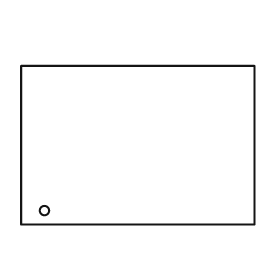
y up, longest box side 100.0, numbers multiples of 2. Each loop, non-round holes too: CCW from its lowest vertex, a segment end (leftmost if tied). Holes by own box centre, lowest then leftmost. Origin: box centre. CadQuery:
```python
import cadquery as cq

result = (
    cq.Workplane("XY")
    .moveTo(-50.0, -34.0)
    .lineTo(50.0, -34.0)
    .lineTo(50.0, 34.0)
    .lineTo(-50.0, 34.0)
    .close()
    .moveTo(-40.0, -28.0)
    .circle(2.0)
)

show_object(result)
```